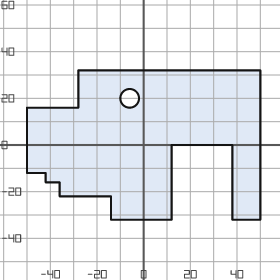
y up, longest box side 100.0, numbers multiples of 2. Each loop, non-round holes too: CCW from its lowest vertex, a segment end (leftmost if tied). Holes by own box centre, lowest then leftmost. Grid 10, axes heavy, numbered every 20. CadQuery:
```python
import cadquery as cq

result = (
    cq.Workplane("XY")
    .moveTo(-14.0, -32.0)
    .lineTo(12.0, -32.0)
    .lineTo(12.0, 0.0)
    .lineTo(38.0, 0.0)
    .lineTo(38.0, -32.0)
    .lineTo(50.0, -32.0)
    .lineTo(50.0, 32.0)
    .lineTo(-28.0, 32.0)
    .lineTo(-28.0, 16.0)
    .lineTo(-50.0, 16.0)
    .lineTo(-50.0, -12.0)
    .lineTo(-42.0, -12.0)
    .lineTo(-42.0, -16.0)
    .lineTo(-36.0, -16.0)
    .lineTo(-36.0, -22.0)
    .lineTo(-14.0, -22.0)
    .close()
    .moveTo(-6.0, 20.0)
    .circle(4.0)
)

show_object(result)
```